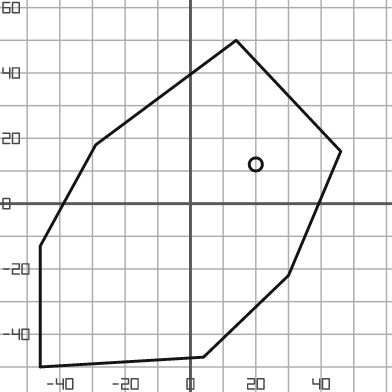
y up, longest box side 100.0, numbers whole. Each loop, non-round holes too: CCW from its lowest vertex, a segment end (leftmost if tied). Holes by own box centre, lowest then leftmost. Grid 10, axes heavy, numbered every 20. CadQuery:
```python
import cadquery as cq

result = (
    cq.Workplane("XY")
    .moveTo(-46.0, -50.0)
    .lineTo(4.0, -47.0)
    .lineTo(30.0, -22.0)
    .lineTo(46.0, 16.0)
    .lineTo(14.0, 50.0)
    .lineTo(-29.0, 18.0)
    .lineTo(-46.0, -13.0)
    .close()
    .moveTo(20.0, 12.0)
    .circle(2.0)
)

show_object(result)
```